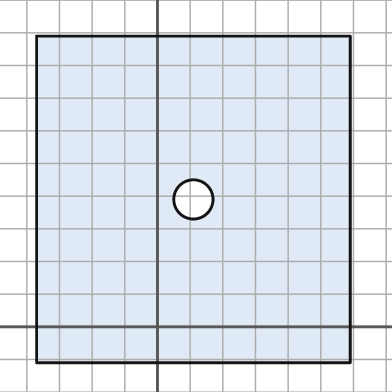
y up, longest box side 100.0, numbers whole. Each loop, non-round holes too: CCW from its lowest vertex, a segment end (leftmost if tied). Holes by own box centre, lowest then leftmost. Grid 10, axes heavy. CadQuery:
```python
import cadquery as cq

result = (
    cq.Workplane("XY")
    .moveTo(-37.0, -11.0)
    .lineTo(59.0, -11.0)
    .lineTo(59.0, 89.0)
    .lineTo(-37.0, 89.0)
    .close()
    .moveTo(11.0, 39.0)
    .circle(6.0)
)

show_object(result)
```